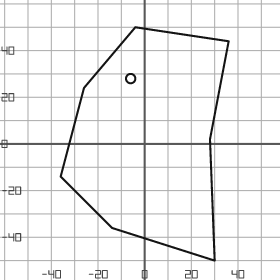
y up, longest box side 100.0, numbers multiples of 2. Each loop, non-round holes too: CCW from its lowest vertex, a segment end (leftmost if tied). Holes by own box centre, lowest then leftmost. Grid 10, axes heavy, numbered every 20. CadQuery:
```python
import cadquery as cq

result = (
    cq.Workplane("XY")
    .moveTo(30.0, -50.0)
    .lineTo(28.0, 2.0)
    .lineTo(36.0, 44.0)
    .lineTo(-4.0, 50.0)
    .lineTo(-26.0, 24.0)
    .lineTo(-36.0, -14.0)
    .lineTo(-14.0, -36.0)
    .close()
    .moveTo(-6.0, 28.0)
    .circle(2.0)
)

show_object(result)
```